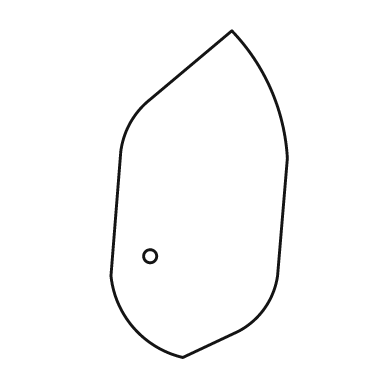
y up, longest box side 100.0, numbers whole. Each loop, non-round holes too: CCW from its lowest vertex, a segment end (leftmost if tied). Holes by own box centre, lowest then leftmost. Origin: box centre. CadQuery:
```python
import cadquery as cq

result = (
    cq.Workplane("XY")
    .moveTo(-5.0, -50.0)
    .lineTo(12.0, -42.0)
    .threePointArc((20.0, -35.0), (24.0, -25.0))
    .lineTo(27.0, 11.0)
    .threePointArc((22.0, 32.0), (10.0, 50.0))
    .lineTo(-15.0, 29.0)
    .threePointArc((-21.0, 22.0), (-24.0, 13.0))
    .lineTo(-27.0, -25.0)
    .threePointArc((-20.0, -41.0), (-5.0, -50.0))
    .close()
    .moveTo(-15.0, -19.0)
    .circle(2.0)
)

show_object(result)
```